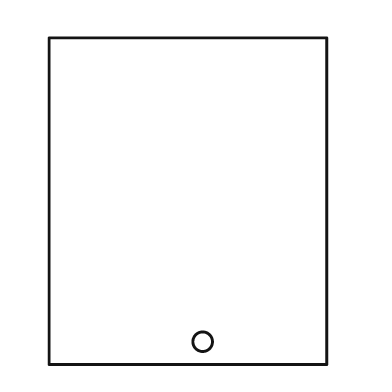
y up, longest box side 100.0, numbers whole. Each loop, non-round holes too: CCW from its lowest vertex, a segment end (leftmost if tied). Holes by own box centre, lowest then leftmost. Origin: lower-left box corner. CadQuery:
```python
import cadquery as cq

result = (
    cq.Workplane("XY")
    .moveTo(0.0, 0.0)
    .lineTo(85.0, 0.0)
    .lineTo(85.0, 100.0)
    .lineTo(0.0, 100.0)
    .close()
    .moveTo(47.0, 7.0)
    .circle(3.0)
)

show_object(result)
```